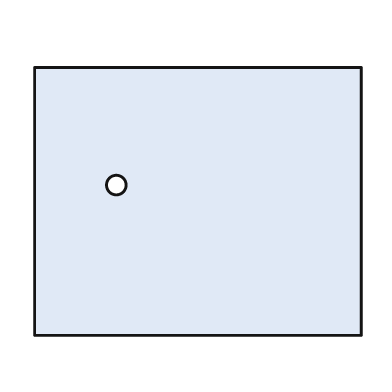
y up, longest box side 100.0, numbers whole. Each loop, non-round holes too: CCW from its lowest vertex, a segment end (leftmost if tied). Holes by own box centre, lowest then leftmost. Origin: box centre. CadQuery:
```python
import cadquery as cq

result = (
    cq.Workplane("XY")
    .moveTo(-50.0, -41.0)
    .lineTo(50.0, -41.0)
    .lineTo(50.0, 41.0)
    .lineTo(-50.0, 41.0)
    .close()
    .moveTo(-25.0, 5.0)
    .circle(3.0)
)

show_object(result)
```